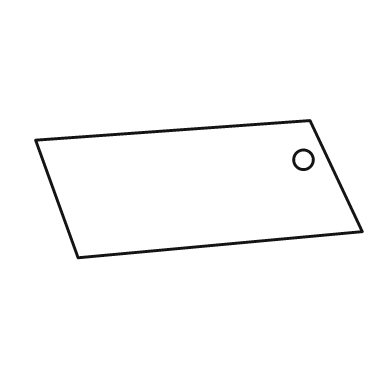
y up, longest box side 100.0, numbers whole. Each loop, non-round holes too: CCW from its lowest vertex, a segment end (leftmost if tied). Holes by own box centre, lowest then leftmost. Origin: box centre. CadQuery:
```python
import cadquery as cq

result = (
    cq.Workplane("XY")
    .moveTo(-37.0, -21.0)
    .lineTo(50.0, -13.0)
    .lineTo(34.0, 21.0)
    .lineTo(-50.0, 15.0)
    .close()
    .moveTo(32.0, 9.0)
    .circle(3.0)
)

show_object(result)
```